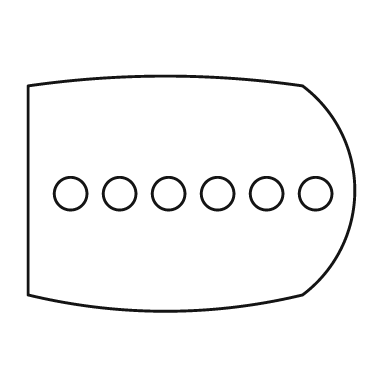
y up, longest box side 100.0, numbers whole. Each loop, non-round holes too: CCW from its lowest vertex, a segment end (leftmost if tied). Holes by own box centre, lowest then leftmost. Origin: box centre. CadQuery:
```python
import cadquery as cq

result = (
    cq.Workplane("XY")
    .moveTo(-50.0, -31.0)
    .threePointArc((-8.0, -36.0), (34.0, -31.0))
    .threePointArc((50.0, 1.0), (34.0, 33.0))
    .threePointArc((-8.0, 36.0), (-50.0, 33.0))
    .close()
    .moveTo(-37.0, 0.0)
    .circle(5.0)
    .moveTo(-22.0, 0.0)
    .circle(5.0)
    .moveTo(-7.0, 0.0)
    .circle(5.0)
    .moveTo(8.0, 0.0)
    .circle(5.0)
    .moveTo(23.0, 0.0)
    .circle(5.0)
    .moveTo(38.0, 0.0)
    .circle(5.0)
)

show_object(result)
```